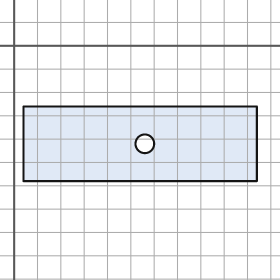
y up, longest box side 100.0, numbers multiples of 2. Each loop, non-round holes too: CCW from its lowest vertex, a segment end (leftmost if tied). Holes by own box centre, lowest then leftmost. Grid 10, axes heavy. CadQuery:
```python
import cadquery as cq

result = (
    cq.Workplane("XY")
    .moveTo(4.0, -58.0)
    .lineTo(104.0, -58.0)
    .lineTo(104.0, -26.0)
    .lineTo(4.0, -26.0)
    .close()
    .moveTo(56.0, -42.0)
    .circle(4.0)
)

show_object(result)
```